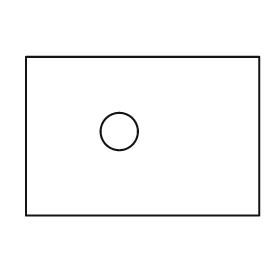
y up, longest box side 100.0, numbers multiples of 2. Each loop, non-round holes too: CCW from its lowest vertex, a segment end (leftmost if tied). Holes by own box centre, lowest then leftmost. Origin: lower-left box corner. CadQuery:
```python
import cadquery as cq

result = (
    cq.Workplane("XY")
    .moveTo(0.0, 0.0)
    .lineTo(100.0, 0.0)
    .lineTo(100.0, 68.0)
    .lineTo(0.0, 68.0)
    .close()
    .moveTo(40.0, 36.0)
    .circle(8.0)
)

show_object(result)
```